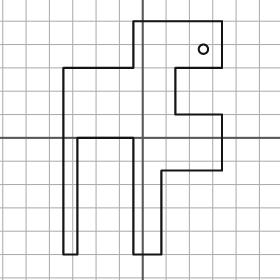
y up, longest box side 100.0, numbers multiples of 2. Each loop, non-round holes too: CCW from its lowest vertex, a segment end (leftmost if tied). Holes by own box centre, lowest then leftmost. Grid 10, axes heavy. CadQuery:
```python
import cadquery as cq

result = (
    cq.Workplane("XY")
    .moveTo(-34.0, -50.0)
    .lineTo(-28.0, -50.0)
    .lineTo(-28.0, 0.0)
    .lineTo(-4.0, 0.0)
    .lineTo(-4.0, -50.0)
    .lineTo(8.0, -50.0)
    .lineTo(8.0, -14.0)
    .lineTo(34.0, -14.0)
    .lineTo(34.0, 10.0)
    .lineTo(14.0, 10.0)
    .lineTo(14.0, 30.0)
    .lineTo(34.0, 30.0)
    .lineTo(34.0, 50.0)
    .lineTo(-4.0, 50.0)
    .lineTo(-4.0, 30.0)
    .lineTo(-34.0, 30.0)
    .close()
    .moveTo(26.0, 38.0)
    .circle(2.0)
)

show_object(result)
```